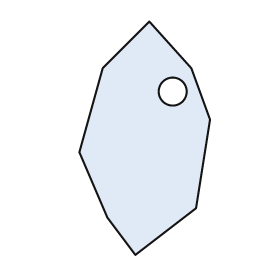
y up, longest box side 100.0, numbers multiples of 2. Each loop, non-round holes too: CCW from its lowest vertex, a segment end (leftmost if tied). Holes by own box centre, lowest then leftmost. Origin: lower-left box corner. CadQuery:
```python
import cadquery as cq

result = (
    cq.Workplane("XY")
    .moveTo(24.0, 0.0)
    .lineTo(50.0, 20.0)
    .lineTo(56.0, 58.0)
    .lineTo(48.0, 80.0)
    .lineTo(30.0, 100.0)
    .lineTo(10.0, 80.0)
    .lineTo(0.0, 44.0)
    .lineTo(12.0, 16.0)
    .close()
    .moveTo(40.0, 70.0)
    .circle(6.0)
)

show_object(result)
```